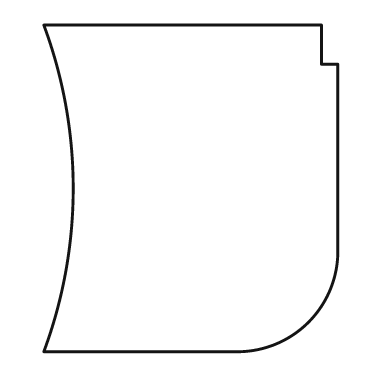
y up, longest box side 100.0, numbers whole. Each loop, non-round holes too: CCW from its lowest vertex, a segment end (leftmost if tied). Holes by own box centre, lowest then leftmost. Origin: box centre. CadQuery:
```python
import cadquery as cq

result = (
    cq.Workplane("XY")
    .moveTo(-45.0, -50.0)
    .lineTo(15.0, -50.0)
    .threePointArc((36.0, -41.0), (45.0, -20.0))
    .lineTo(45.0, 38.0)
    .lineTo(40.0, 38.0)
    .lineTo(40.0, 50.0)
    .lineTo(-45.0, 50.0)
    .threePointArc((-36.0, 0.0), (-45.0, -50.0))
    .close()
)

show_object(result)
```